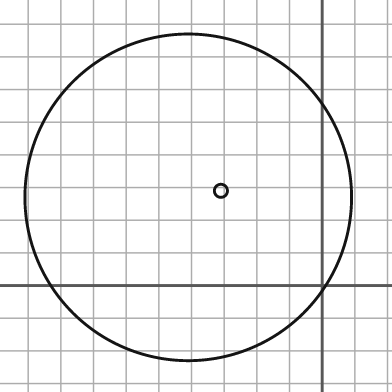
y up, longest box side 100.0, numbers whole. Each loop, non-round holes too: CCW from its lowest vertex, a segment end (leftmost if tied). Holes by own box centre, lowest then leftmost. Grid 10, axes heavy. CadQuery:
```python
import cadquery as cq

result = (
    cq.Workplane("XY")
    .moveTo(-41.0, 27.0)
    .circle(50.0)
    .moveTo(-31.0, 29.0)
    .circle(2.0)
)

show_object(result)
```